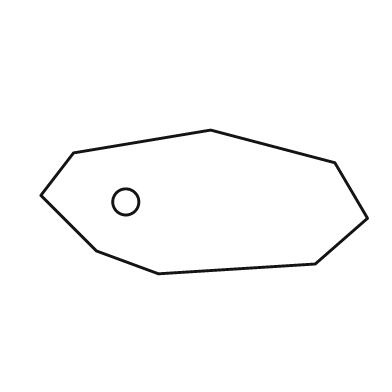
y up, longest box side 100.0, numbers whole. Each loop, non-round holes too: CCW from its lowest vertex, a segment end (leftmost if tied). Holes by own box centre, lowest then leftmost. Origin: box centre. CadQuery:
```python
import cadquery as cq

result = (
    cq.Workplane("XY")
    .moveTo(-14.0, -22.0)
    .lineTo(34.0, -19.0)
    .lineTo(50.0, -5.0)
    .lineTo(40.0, 12.0)
    .lineTo(2.0, 22.0)
    .lineTo(-40.0, 15.0)
    .lineTo(-50.0, 2.0)
    .lineTo(-33.0, -15.0)
    .close()
    .moveTo(-24.0, 0.0)
    .circle(4.0)
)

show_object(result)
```